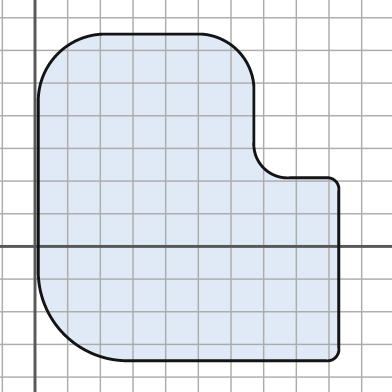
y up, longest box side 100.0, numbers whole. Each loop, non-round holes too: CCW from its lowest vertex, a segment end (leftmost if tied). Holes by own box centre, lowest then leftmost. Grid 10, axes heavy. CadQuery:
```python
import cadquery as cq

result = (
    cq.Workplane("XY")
    .moveTo(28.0, -35.0)
    .lineTo(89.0, -35.0)
    .threePointArc((92.0, -34.0), (93.0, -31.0))
    .lineTo(93.0, 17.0)
    .threePointArc((92.0, 20.0), (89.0, 21.0))
    .lineTo(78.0, 21.0)
    .threePointArc((70.0, 24.0), (67.0, 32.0))
    .lineTo(67.0, 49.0)
    .threePointArc((62.0, 60.0), (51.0, 65.0))
    .lineTo(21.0, 65.0)
    .threePointArc((7.0, 59.0), (1.0, 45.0))
    .lineTo(1.0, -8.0)
    .threePointArc((9.0, -27.0), (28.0, -35.0))
    .close()
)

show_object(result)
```